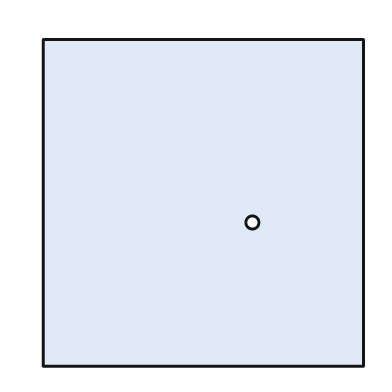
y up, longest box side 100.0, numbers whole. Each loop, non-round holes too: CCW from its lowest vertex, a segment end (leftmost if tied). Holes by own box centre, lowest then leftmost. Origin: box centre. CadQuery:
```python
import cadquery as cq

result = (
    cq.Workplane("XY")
    .moveTo(-49.0, -50.0)
    .lineTo(49.0, -50.0)
    .lineTo(49.0, 50.0)
    .lineTo(-49.0, 50.0)
    .close()
    .moveTo(15.0, -6.0)
    .circle(2.0)
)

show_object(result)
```